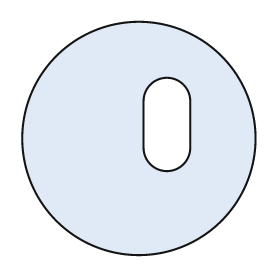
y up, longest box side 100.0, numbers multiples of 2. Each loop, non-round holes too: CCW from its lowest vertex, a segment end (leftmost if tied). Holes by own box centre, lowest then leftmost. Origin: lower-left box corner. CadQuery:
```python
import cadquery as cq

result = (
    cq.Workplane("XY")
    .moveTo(50.0, 50.0)
    .circle(50.0)
    .moveTo(52.0, 46.0)
    .threePointArc((62.0, 36.0), (72.0, 46.0))
    .lineTo(72.0, 66.0)
    .threePointArc((62.0, 76.0), (52.0, 66.0))
    .close()
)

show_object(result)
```